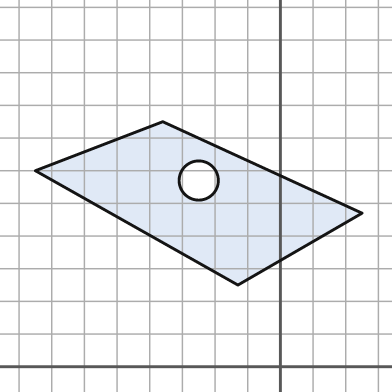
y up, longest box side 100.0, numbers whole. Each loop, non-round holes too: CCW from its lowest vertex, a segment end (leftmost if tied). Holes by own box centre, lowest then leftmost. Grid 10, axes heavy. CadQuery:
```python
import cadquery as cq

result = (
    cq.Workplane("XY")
    .moveTo(-13.0, 25.0)
    .lineTo(25.0, 47.0)
    .lineTo(-36.0, 75.0)
    .lineTo(-75.0, 60.0)
    .close()
    .moveTo(-25.0, 57.0)
    .circle(6.0)
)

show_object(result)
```